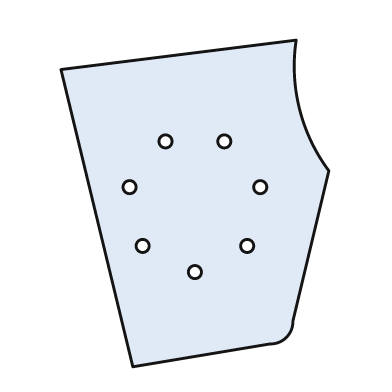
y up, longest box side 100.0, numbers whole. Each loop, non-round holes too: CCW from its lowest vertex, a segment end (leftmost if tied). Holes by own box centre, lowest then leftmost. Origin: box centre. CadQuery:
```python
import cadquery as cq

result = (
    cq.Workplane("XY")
    .moveTo(-19.0, -50.0)
    .lineTo(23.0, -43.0)
    .threePointArc((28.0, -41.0), (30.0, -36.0))
    .lineTo(41.0, 10.0)
    .threePointArc((32.0, 29.0), (31.0, 50.0))
    .lineTo(-41.0, 41.0)
    .close()
    .moveTo(0.0, -21.0)
    .circle(2.0)
    .moveTo(-16.0, -13.0)
    .circle(2.0)
    .moveTo(16.0, -13.0)
    .circle(2.0)
    .moveTo(-20.0, 5.0)
    .circle(2.0)
    .moveTo(20.0, 5.0)
    .circle(2.0)
    .moveTo(-9.0, 19.0)
    .circle(2.0)
    .moveTo(9.0, 19.0)
    .circle(2.0)
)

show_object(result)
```